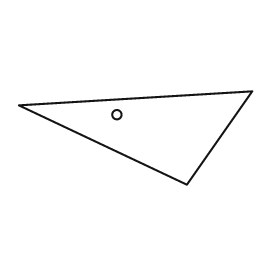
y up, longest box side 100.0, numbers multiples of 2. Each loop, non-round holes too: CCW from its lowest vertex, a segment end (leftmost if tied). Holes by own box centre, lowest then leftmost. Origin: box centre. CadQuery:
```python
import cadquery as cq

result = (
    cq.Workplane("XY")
    .moveTo(22.0, -20.0)
    .lineTo(50.0, 20.0)
    .lineTo(-50.0, 14.0)
    .close()
    .moveTo(-8.0, 10.0)
    .circle(2.0)
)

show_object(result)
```